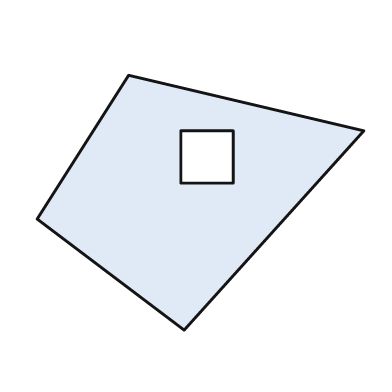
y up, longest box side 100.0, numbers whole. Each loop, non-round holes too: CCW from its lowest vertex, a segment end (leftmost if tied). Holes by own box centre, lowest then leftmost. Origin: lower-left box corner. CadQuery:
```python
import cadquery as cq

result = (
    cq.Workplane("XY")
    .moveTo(45.0, 0.0)
    .lineTo(100.0, 61.0)
    .lineTo(28.0, 78.0)
    .lineTo(0.0, 34.0)
    .close()
    .moveTo(44.0, 45.0)
    .lineTo(60.0, 45.0)
    .lineTo(60.0, 61.0)
    .lineTo(44.0, 61.0)
    .close()
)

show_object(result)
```